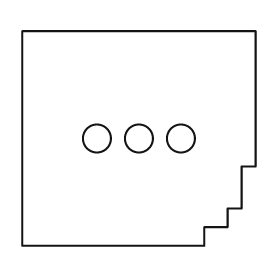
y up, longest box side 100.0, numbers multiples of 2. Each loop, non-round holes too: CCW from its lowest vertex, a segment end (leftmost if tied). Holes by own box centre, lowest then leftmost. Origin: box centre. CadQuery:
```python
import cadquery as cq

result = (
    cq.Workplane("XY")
    .moveTo(-50.0, -46.0)
    .lineTo(28.0, -46.0)
    .lineTo(28.0, -38.0)
    .lineTo(38.0, -38.0)
    .lineTo(38.0, -30.0)
    .lineTo(44.0, -30.0)
    .lineTo(44.0, -12.0)
    .lineTo(50.0, -12.0)
    .lineTo(50.0, 46.0)
    .lineTo(-50.0, 46.0)
    .close()
    .moveTo(-18.0, 0.0)
    .circle(6.0)
    .moveTo(0.0, 0.0)
    .circle(6.0)
    .moveTo(18.0, 0.0)
    .circle(6.0)
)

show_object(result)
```